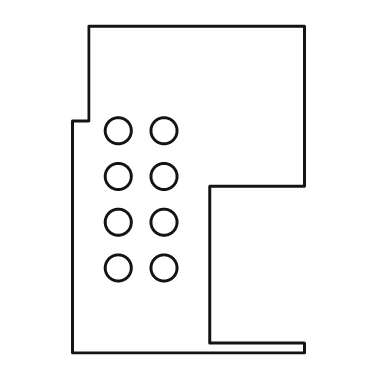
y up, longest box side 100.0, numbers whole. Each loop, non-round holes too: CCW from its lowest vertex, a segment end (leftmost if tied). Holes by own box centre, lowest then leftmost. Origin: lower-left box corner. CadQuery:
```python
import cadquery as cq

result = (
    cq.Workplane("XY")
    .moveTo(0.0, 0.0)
    .lineTo(71.0, 0.0)
    .lineTo(71.0, 3.0)
    .lineTo(42.0, 3.0)
    .lineTo(42.0, 51.0)
    .lineTo(71.0, 51.0)
    .lineTo(71.0, 100.0)
    .lineTo(5.0, 100.0)
    .lineTo(5.0, 71.0)
    .lineTo(0.0, 71.0)
    .close()
    .moveTo(14.0, 26.0)
    .circle(4.0)
    .moveTo(28.0, 26.0)
    .circle(4.0)
    .moveTo(14.0, 40.0)
    .circle(4.0)
    .moveTo(28.0, 40.0)
    .circle(4.0)
    .moveTo(14.0, 54.0)
    .circle(4.0)
    .moveTo(28.0, 54.0)
    .circle(4.0)
    .moveTo(14.0, 68.0)
    .circle(4.0)
    .moveTo(28.0, 68.0)
    .circle(4.0)
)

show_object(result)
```